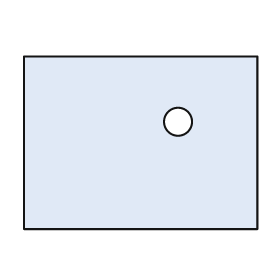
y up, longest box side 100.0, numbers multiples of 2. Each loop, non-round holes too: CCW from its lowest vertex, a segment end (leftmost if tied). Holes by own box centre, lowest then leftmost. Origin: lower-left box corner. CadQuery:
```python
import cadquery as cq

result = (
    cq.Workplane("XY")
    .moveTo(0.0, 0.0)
    .lineTo(100.0, 0.0)
    .lineTo(100.0, 74.0)
    .lineTo(0.0, 74.0)
    .close()
    .moveTo(66.0, 46.0)
    .circle(6.0)
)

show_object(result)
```